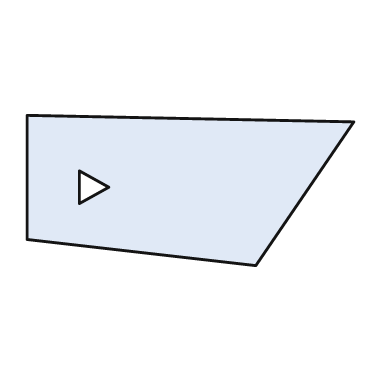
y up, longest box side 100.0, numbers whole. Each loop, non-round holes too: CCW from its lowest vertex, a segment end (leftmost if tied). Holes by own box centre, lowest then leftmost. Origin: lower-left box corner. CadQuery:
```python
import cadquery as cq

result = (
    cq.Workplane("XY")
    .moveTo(70.0, 0.0)
    .lineTo(100.0, 44.0)
    .lineTo(0.0, 46.0)
    .lineTo(0.0, 8.0)
    .close()
    .moveTo(16.0, 19.0)
    .lineTo(25.0, 24.0)
    .lineTo(16.0, 29.0)
    .close()
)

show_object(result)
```